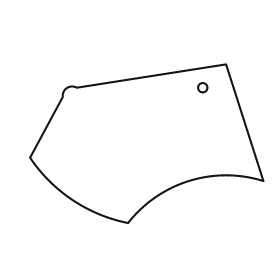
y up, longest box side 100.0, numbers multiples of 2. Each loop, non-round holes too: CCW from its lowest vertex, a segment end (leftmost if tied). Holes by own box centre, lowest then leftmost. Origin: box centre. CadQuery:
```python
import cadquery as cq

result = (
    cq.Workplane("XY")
    .moveTo(-8.0, -34.0)
    .threePointArc((18.0, -16.0), (50.0, -16.0))
    .lineTo(34.0, 34.0)
    .lineTo(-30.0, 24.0)
    .threePointArc((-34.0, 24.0), (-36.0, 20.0))
    .lineTo(-50.0, -6.0)
    .threePointArc((-32.0, -24.0), (-8.0, -34.0))
    .close()
    .moveTo(24.0, 24.0)
    .circle(2.0)
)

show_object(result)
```